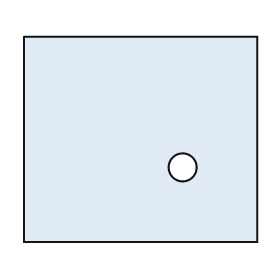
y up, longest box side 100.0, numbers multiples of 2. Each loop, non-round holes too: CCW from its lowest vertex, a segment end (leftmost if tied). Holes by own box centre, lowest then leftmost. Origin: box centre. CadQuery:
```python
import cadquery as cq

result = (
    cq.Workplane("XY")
    .moveTo(-50.0, -44.0)
    .lineTo(50.0, -44.0)
    .lineTo(50.0, 44.0)
    .lineTo(-50.0, 44.0)
    .close()
    .moveTo(18.0, -12.0)
    .circle(6.0)
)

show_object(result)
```